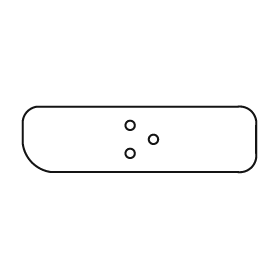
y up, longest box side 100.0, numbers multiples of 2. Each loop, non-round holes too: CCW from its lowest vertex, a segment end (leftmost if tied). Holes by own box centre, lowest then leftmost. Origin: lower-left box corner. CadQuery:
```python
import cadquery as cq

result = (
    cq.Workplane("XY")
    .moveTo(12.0, 0.0)
    .lineTo(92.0, 0.0)
    .threePointArc((98.0, 2.0), (100.0, 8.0))
    .lineTo(100.0, 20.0)
    .threePointArc((98.0, 26.0), (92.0, 28.0))
    .lineTo(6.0, 28.0)
    .threePointArc((2.0, 26.0), (0.0, 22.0))
    .lineTo(0.0, 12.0)
    .threePointArc((4.0, 4.0), (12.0, 0.0))
    .close()
    .moveTo(46.0, 8.0)
    .circle(2.0)
    .moveTo(56.0, 14.0)
    .circle(2.0)
    .moveTo(46.0, 20.0)
    .circle(2.0)
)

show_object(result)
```